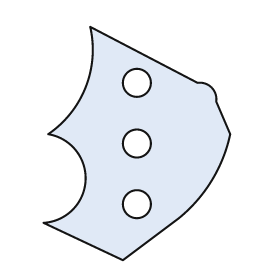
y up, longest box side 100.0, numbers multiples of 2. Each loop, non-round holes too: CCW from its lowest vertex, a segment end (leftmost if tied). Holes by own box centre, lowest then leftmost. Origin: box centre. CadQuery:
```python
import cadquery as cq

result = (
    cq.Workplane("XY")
    .moveTo(-6.0, -50.0)
    .lineTo(18.0, -32.0)
    .threePointArc((32.0, -16.0), (40.0, 4.0))
    .lineTo(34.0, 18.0)
    .threePointArc((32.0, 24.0), (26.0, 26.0))
    .lineTo(-20.0, 50.0)
    .threePointArc((-22.0, 24.0), (-38.0, 4.0))
    .threePointArc((-22.0, -16.0), (-40.0, -34.0))
    .close()
    .moveTo(0.0, -26.0)
    .circle(6.0)
    .moveTo(0.0, 0.0)
    .circle(6.0)
    .moveTo(0.0, 26.0)
    .circle(6.0)
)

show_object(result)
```